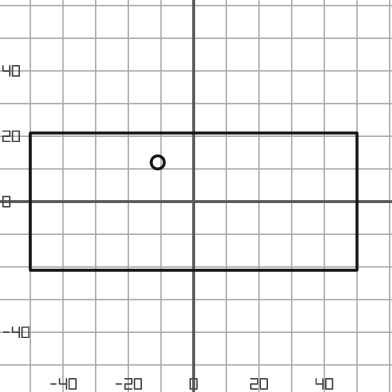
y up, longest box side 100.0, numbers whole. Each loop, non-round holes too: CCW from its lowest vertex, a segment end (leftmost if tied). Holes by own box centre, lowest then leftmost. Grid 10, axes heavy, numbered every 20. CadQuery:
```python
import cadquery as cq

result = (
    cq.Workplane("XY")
    .moveTo(-50.0, -21.0)
    .lineTo(50.0, -21.0)
    .lineTo(50.0, 21.0)
    .lineTo(-50.0, 21.0)
    .close()
    .moveTo(-11.0, 12.0)
    .circle(2.0)
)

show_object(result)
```